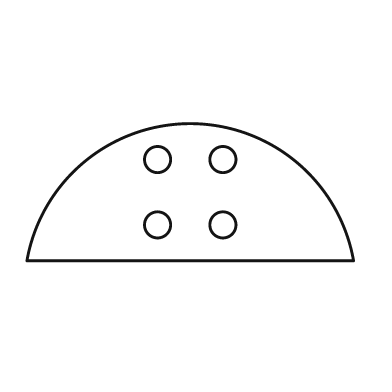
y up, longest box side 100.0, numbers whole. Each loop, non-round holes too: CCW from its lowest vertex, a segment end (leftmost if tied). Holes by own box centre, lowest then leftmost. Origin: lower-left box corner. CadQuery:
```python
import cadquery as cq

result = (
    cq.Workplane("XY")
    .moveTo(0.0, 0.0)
    .lineTo(100.0, 0.0)
    .threePointArc((50.0, 42.0), (0.0, 0.0))
    .close()
    .moveTo(40.0, 11.0)
    .circle(4.0)
    .moveTo(60.0, 11.0)
    .circle(4.0)
    .moveTo(40.0, 31.0)
    .circle(4.0)
    .moveTo(60.0, 31.0)
    .circle(4.0)
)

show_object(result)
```